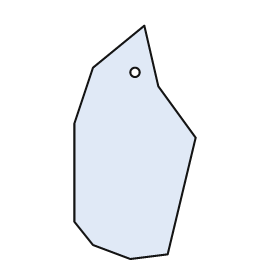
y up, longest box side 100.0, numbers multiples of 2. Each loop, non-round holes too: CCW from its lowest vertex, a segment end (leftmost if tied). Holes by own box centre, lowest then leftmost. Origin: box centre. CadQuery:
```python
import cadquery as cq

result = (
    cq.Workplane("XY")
    .moveTo(-2.0, -50.0)
    .lineTo(14.0, -48.0)
    .lineTo(26.0, 2.0)
    .lineTo(10.0, 24.0)
    .lineTo(4.0, 50.0)
    .lineTo(-18.0, 32.0)
    .lineTo(-26.0, 8.0)
    .lineTo(-26.0, -34.0)
    .lineTo(-18.0, -44.0)
    .close()
    .moveTo(0.0, 30.0)
    .circle(2.0)
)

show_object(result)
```